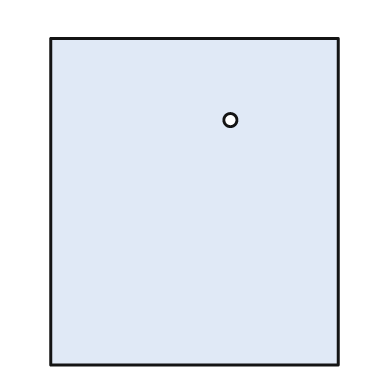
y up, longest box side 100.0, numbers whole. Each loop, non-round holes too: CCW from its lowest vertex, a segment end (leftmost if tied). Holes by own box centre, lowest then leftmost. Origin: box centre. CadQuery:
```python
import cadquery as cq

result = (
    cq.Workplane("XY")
    .moveTo(-44.0, -50.0)
    .lineTo(44.0, -50.0)
    .lineTo(44.0, 50.0)
    .lineTo(-44.0, 50.0)
    .close()
    .moveTo(11.0, 25.0)
    .circle(2.0)
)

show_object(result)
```